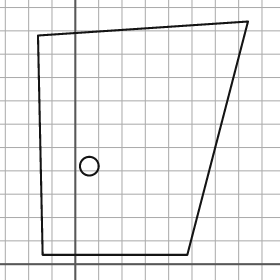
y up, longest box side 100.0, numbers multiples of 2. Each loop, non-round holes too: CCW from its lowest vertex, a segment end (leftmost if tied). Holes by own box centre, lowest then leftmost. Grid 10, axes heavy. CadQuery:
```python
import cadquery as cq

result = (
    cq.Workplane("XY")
    .moveTo(-14.0, 4.0)
    .lineTo(48.0, 4.0)
    .lineTo(74.0, 104.0)
    .lineTo(-16.0, 98.0)
    .close()
    .moveTo(6.0, 42.0)
    .circle(4.0)
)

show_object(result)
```